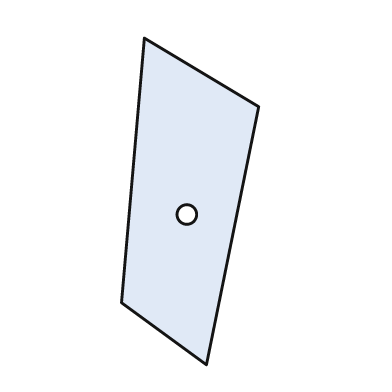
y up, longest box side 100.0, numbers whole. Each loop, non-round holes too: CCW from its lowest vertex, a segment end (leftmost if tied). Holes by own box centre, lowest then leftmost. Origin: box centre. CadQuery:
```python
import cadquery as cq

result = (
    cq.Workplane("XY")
    .moveTo(5.0, -50.0)
    .lineTo(21.0, 29.0)
    .lineTo(-14.0, 50.0)
    .lineTo(-21.0, -31.0)
    .close()
    .moveTo(-1.0, -4.0)
    .circle(3.0)
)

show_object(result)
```